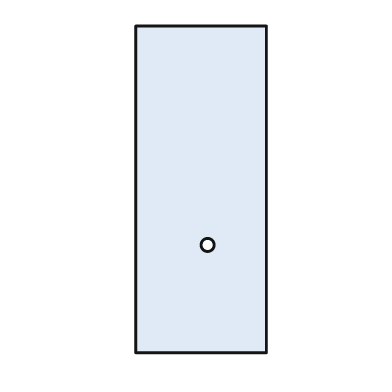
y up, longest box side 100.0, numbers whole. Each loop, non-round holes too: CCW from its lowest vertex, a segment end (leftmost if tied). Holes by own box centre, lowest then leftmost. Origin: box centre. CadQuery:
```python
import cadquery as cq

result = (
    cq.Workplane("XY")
    .moveTo(-20.0, -50.0)
    .lineTo(20.0, -50.0)
    .lineTo(20.0, 50.0)
    .lineTo(-20.0, 50.0)
    .close()
    .moveTo(2.0, -17.0)
    .circle(2.0)
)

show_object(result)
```